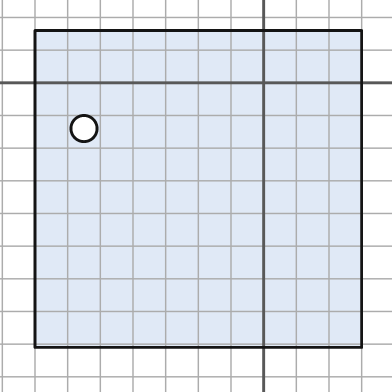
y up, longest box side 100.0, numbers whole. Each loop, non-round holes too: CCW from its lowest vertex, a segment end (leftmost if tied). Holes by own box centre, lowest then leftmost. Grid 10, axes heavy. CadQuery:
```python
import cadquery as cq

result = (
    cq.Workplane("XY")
    .moveTo(-70.0, -81.0)
    .lineTo(30.0, -81.0)
    .lineTo(30.0, 16.0)
    .lineTo(-70.0, 16.0)
    .close()
    .moveTo(-55.0, -14.0)
    .circle(4.0)
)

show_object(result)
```